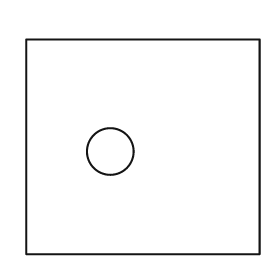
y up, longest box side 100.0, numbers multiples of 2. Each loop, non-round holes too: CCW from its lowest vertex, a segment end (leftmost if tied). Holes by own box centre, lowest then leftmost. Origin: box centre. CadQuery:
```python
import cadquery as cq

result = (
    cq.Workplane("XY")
    .moveTo(-50.0, -46.0)
    .lineTo(50.0, -46.0)
    .lineTo(50.0, 46.0)
    .lineTo(-50.0, 46.0)
    .close()
    .moveTo(-14.0, -2.0)
    .circle(10.0)
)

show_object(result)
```